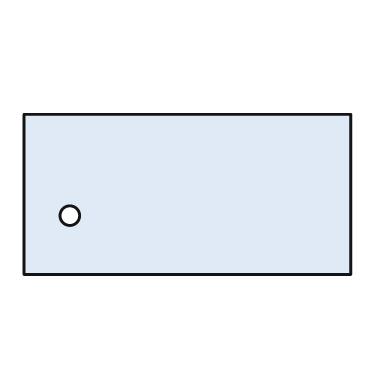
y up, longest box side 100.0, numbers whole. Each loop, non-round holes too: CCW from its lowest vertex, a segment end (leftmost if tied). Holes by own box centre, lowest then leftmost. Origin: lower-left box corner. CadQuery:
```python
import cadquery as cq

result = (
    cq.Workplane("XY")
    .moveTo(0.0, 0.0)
    .lineTo(100.0, 0.0)
    .lineTo(100.0, 49.0)
    .lineTo(0.0, 49.0)
    .close()
    .moveTo(14.0, 18.0)
    .circle(3.0)
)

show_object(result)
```